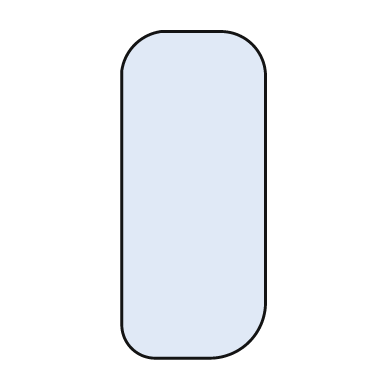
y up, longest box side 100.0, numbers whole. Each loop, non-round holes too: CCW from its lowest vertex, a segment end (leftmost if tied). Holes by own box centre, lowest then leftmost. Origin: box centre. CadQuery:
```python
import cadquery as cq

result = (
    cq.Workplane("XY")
    .moveTo(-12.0, -50.0)
    .lineTo(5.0, -50.0)
    .threePointArc((17.0, -45.0), (22.0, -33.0))
    .lineTo(22.0, 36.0)
    .threePointArc((18.0, 46.0), (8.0, 50.0))
    .lineTo(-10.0, 50.0)
    .threePointArc((-18.0, 46.0), (-22.0, 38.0))
    .lineTo(-22.0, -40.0)
    .threePointArc((-19.0, -47.0), (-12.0, -50.0))
    .close()
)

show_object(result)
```